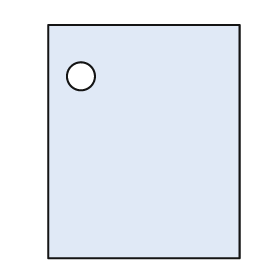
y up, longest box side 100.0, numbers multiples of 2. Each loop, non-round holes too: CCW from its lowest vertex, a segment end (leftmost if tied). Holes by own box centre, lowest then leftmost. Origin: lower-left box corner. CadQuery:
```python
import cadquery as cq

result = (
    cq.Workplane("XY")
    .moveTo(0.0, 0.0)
    .lineTo(82.0, 0.0)
    .lineTo(82.0, 100.0)
    .lineTo(0.0, 100.0)
    .close()
    .moveTo(14.0, 78.0)
    .circle(6.0)
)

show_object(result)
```